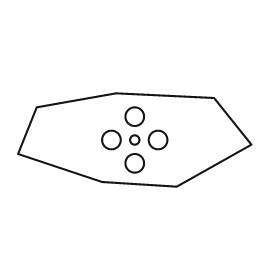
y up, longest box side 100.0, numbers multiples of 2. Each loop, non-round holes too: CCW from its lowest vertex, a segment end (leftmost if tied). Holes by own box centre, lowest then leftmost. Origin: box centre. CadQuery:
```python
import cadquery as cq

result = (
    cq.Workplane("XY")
    .moveTo(18.0, -20.0)
    .lineTo(50.0, -2.0)
    .lineTo(34.0, 18.0)
    .lineTo(-8.0, 20.0)
    .lineTo(-42.0, 14.0)
    .lineTo(-50.0, -6.0)
    .lineTo(-14.0, -18.0)
    .close()
    .moveTo(0.0, -10.0)
    .circle(4.0)
    .moveTo(-10.0, 0.0)
    .circle(4.0)
    .moveTo(0.0, 0.0)
    .circle(2.0)
    .moveTo(10.0, 0.0)
    .circle(4.0)
    .moveTo(0.0, 10.0)
    .circle(4.0)
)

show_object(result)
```